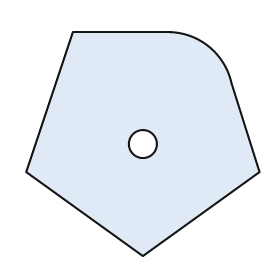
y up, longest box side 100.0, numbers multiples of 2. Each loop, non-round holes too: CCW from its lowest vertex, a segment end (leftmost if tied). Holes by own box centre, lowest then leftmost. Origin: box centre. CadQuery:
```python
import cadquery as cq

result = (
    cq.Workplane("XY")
    .moveTo(0.0, -48.0)
    .lineTo(50.0, -12.0)
    .lineTo(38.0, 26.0)
    .threePointArc((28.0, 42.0), (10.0, 48.0))
    .lineTo(-30.0, 48.0)
    .lineTo(-50.0, -12.0)
    .close()
    .moveTo(0.0, 0.0)
    .circle(6.0)
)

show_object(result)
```